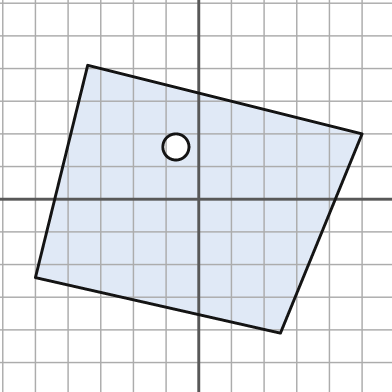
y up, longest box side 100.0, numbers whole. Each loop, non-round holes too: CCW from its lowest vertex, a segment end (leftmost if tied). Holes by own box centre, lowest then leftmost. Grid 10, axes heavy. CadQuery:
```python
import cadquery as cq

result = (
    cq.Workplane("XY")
    .moveTo(25.0, -41.0)
    .lineTo(50.0, 20.0)
    .lineTo(-34.0, 41.0)
    .lineTo(-50.0, -24.0)
    .close()
    .moveTo(-7.0, 16.0)
    .circle(4.0)
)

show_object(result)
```